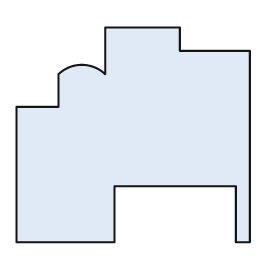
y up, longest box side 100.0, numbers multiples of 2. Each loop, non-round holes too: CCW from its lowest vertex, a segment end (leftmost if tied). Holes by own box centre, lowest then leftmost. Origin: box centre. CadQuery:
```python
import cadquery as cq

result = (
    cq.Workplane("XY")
    .moveTo(-50.0, -46.0)
    .lineTo(-8.0, -46.0)
    .lineTo(-8.0, -22.0)
    .lineTo(44.0, -22.0)
    .lineTo(44.0, -46.0)
    .lineTo(50.0, -46.0)
    .lineTo(50.0, 36.0)
    .lineTo(20.0, 36.0)
    .lineTo(20.0, 46.0)
    .lineTo(-12.0, 46.0)
    .lineTo(-12.0, 26.0)
    .threePointArc((-22.0, 30.0), (-32.0, 26.0))
    .lineTo(-32.0, 12.0)
    .lineTo(-50.0, 12.0)
    .close()
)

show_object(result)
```